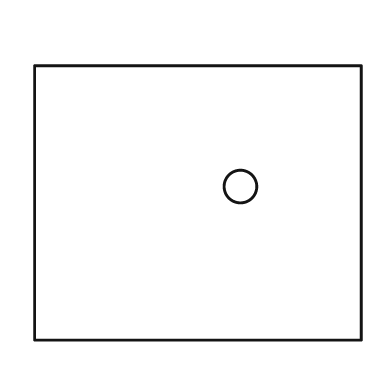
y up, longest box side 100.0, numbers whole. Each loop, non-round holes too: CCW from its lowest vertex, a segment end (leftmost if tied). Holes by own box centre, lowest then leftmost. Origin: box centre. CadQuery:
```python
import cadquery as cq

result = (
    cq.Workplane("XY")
    .moveTo(-50.0, -42.0)
    .lineTo(50.0, -42.0)
    .lineTo(50.0, 42.0)
    .lineTo(-50.0, 42.0)
    .close()
    .moveTo(13.0, 5.0)
    .circle(5.0)
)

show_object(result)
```